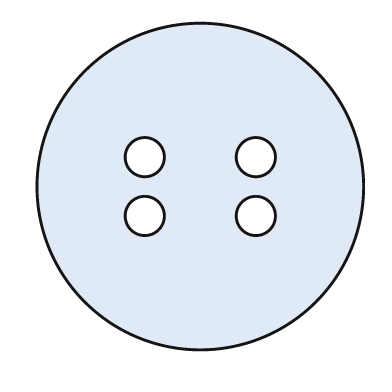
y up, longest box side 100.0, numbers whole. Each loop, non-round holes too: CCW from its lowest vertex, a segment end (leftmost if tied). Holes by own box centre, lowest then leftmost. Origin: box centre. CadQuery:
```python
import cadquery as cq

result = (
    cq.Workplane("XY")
    .moveTo(0.0, 0.0)
    .circle(50.0)
    .moveTo(-17.0, -9.0)
    .circle(6.0)
    .moveTo(17.0, -9.0)
    .circle(6.0)
    .moveTo(-17.0, 9.0)
    .circle(6.0)
    .moveTo(17.0, 9.0)
    .circle(6.0)
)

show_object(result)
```